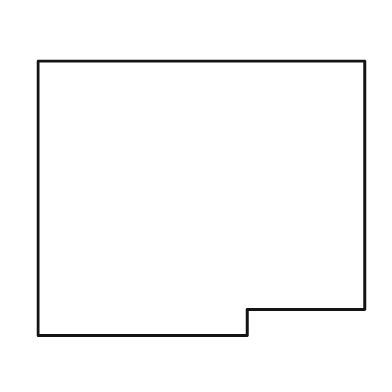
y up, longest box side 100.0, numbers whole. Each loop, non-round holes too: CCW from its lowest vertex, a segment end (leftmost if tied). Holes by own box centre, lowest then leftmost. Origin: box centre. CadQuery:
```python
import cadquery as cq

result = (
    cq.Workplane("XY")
    .moveTo(-50.0, -42.0)
    .lineTo(14.0, -42.0)
    .lineTo(14.0, -34.0)
    .lineTo(50.0, -34.0)
    .lineTo(50.0, 42.0)
    .lineTo(-50.0, 42.0)
    .close()
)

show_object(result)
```